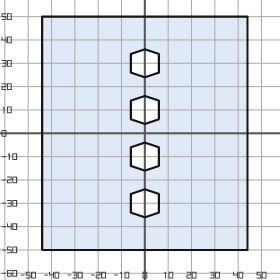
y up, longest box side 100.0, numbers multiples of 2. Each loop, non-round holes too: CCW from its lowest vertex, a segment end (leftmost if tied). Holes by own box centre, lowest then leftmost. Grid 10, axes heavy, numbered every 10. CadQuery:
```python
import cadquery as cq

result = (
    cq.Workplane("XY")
    .moveTo(-44.0, -50.0)
    .lineTo(44.0, -50.0)
    .lineTo(44.0, 50.0)
    .lineTo(-44.0, 50.0)
    .close()
    .moveTo(0.0, -36.0)
    .lineTo(6.0, -34.0)
    .lineTo(6.0, -26.0)
    .lineTo(0.0, -24.0)
    .lineTo(-6.0, -26.0)
    .lineTo(-6.0, -34.0)
    .close()
    .moveTo(0.0, -16.0)
    .lineTo(6.0, -14.0)
    .lineTo(6.0, -6.0)
    .lineTo(0.0, -4.0)
    .lineTo(-6.0, -6.0)
    .lineTo(-6.0, -14.0)
    .close()
    .moveTo(0.0, 4.0)
    .lineTo(6.0, 6.0)
    .lineTo(6.0, 14.0)
    .lineTo(0.0, 16.0)
    .lineTo(-6.0, 14.0)
    .lineTo(-6.0, 6.0)
    .close()
    .moveTo(0.0, 24.0)
    .lineTo(6.0, 26.0)
    .lineTo(6.0, 34.0)
    .lineTo(0.0, 36.0)
    .lineTo(-6.0, 34.0)
    .lineTo(-6.0, 26.0)
    .close()
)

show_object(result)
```